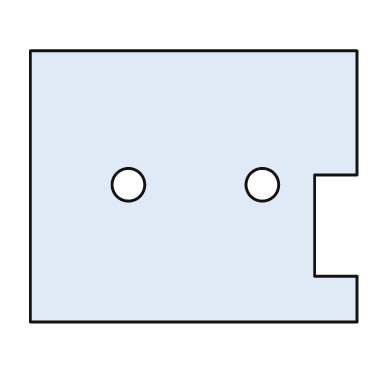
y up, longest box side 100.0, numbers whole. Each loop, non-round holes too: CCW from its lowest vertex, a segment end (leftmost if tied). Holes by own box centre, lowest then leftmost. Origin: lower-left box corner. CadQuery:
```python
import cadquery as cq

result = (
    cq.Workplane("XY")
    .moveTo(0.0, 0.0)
    .lineTo(100.0, 0.0)
    .lineTo(100.0, 14.0)
    .lineTo(87.0, 14.0)
    .lineTo(87.0, 45.0)
    .lineTo(100.0, 45.0)
    .lineTo(100.0, 83.0)
    .lineTo(0.0, 83.0)
    .close()
    .moveTo(30.0, 42.0)
    .circle(5.0)
    .moveTo(71.0, 42.0)
    .circle(5.0)
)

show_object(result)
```